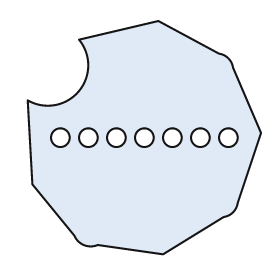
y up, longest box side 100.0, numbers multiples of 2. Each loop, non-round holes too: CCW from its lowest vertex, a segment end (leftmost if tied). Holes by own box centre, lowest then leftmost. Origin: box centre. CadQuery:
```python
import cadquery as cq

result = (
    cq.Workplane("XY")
    .moveTo(8.0, -50.0)
    .lineTo(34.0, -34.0)
    .threePointArc((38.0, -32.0), (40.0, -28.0))
    .lineTo(50.0, 2.0)
    .lineTo(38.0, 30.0)
    .threePointArc((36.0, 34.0), (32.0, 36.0))
    .lineTo(6.0, 50.0)
    .lineTo(-28.0, 42.0)
    .threePointArc((-28.0, 20.0), (-50.0, 16.0))
    .lineTo(-48.0, -20.0)
    .lineTo(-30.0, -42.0)
    .threePointArc((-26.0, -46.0), (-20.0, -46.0))
    .close()
    .moveTo(-36.0, 0.0)
    .circle(4.0)
    .moveTo(-24.0, 0.0)
    .circle(4.0)
    .moveTo(-12.0, 0.0)
    .circle(4.0)
    .moveTo(0.0, 0.0)
    .circle(4.0)
    .moveTo(12.0, 0.0)
    .circle(4.0)
    .moveTo(24.0, 0.0)
    .circle(4.0)
    .moveTo(36.0, 0.0)
    .circle(4.0)
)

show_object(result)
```